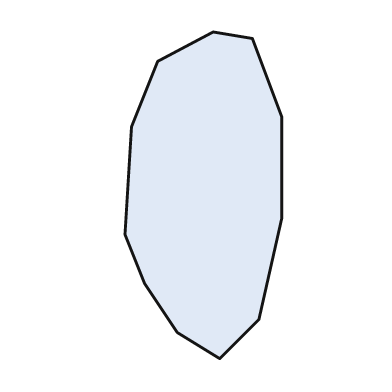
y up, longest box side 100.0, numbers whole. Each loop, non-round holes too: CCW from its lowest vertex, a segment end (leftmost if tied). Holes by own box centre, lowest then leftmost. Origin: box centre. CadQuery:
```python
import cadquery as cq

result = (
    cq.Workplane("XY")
    .moveTo(5.0, -50.0)
    .lineTo(17.0, -38.0)
    .lineTo(24.0, -7.0)
    .lineTo(24.0, 24.0)
    .lineTo(15.0, 48.0)
    .lineTo(3.0, 50.0)
    .lineTo(-14.0, 41.0)
    .lineTo(-22.0, 21.0)
    .lineTo(-24.0, -12.0)
    .lineTo(-18.0, -27.0)
    .lineTo(-8.0, -42.0)
    .close()
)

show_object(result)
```